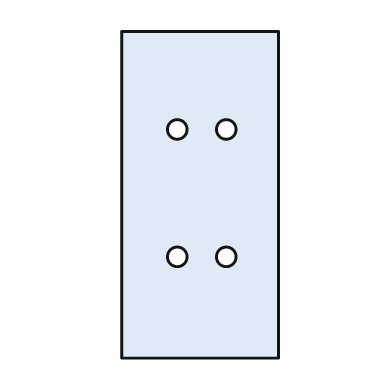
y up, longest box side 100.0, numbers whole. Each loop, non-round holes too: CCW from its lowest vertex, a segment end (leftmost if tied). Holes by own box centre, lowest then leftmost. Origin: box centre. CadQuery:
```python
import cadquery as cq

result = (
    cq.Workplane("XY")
    .moveTo(-24.0, -50.0)
    .lineTo(24.0, -50.0)
    .lineTo(24.0, 50.0)
    .lineTo(-24.0, 50.0)
    .close()
    .moveTo(-7.0, -19.0)
    .circle(3.0)
    .moveTo(8.0, -19.0)
    .circle(3.0)
    .moveTo(-7.0, 20.0)
    .circle(3.0)
    .moveTo(8.0, 20.0)
    .circle(3.0)
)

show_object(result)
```